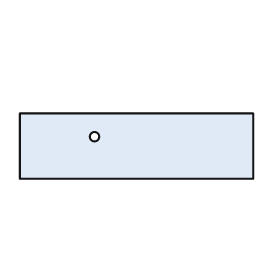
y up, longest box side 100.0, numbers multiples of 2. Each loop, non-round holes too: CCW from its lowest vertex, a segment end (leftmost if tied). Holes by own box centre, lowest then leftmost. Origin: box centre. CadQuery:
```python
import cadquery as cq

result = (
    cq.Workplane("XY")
    .moveTo(-50.0, -14.0)
    .lineTo(50.0, -14.0)
    .lineTo(50.0, 14.0)
    .lineTo(-50.0, 14.0)
    .close()
    .moveTo(-18.0, 4.0)
    .circle(2.0)
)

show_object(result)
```